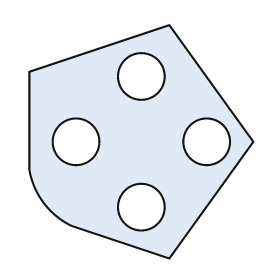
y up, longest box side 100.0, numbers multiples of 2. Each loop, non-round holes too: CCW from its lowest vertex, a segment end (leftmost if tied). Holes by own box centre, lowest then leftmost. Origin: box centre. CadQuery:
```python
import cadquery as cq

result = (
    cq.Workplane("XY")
    .moveTo(12.0, -50.0)
    .lineTo(48.0, 0.0)
    .lineTo(12.0, 50.0)
    .lineTo(-48.0, 30.0)
    .lineTo(-48.0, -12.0)
    .threePointArc((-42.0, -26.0), (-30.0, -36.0))
    .close()
    .moveTo(0.0, -28.0)
    .circle(10.0)
    .moveTo(-28.0, 0.0)
    .circle(10.0)
    .moveTo(28.0, 0.0)
    .circle(10.0)
    .moveTo(0.0, 28.0)
    .circle(10.0)
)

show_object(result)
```